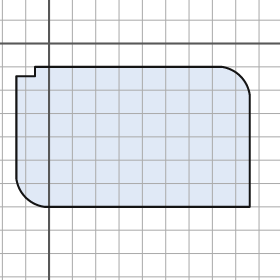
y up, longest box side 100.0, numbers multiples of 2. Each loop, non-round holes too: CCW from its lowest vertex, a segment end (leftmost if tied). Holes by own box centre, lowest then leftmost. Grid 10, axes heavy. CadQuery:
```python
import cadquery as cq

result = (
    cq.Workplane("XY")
    .moveTo(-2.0, -70.0)
    .lineTo(86.0, -70.0)
    .lineTo(86.0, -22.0)
    .threePointArc((82.0, -14.0), (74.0, -10.0))
    .lineTo(-6.0, -10.0)
    .lineTo(-6.0, -14.0)
    .lineTo(-14.0, -14.0)
    .lineTo(-14.0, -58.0)
    .threePointArc((-10.0, -66.0), (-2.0, -70.0))
    .close()
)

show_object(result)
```